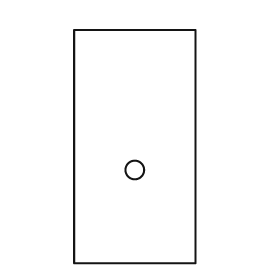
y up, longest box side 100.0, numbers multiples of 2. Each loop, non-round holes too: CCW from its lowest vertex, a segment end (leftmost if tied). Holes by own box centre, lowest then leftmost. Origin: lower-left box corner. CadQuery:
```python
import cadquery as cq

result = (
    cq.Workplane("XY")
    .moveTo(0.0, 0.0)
    .lineTo(52.0, 0.0)
    .lineTo(52.0, 100.0)
    .lineTo(0.0, 100.0)
    .close()
    .moveTo(26.0, 40.0)
    .circle(4.0)
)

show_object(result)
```